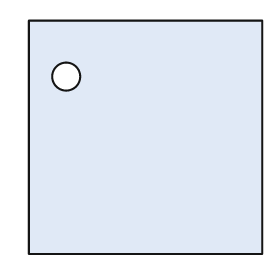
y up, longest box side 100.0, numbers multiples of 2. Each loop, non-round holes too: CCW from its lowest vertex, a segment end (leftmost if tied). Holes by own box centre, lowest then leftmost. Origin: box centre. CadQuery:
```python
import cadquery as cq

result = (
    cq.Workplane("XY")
    .moveTo(-50.0, -50.0)
    .lineTo(50.0, -50.0)
    .lineTo(50.0, 50.0)
    .lineTo(-50.0, 50.0)
    .close()
    .moveTo(-34.0, 26.0)
    .circle(6.0)
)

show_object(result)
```